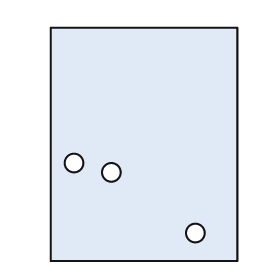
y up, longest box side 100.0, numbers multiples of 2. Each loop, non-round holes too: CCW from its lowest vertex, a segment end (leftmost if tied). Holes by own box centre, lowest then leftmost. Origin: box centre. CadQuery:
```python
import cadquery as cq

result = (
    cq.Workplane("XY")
    .moveTo(-40.0, -50.0)
    .lineTo(40.0, -50.0)
    .lineTo(40.0, 50.0)
    .lineTo(-40.0, 50.0)
    .close()
    .moveTo(22.0, -38.0)
    .circle(4.0)
    .moveTo(-14.0, -12.0)
    .circle(4.0)
    .moveTo(-30.0, -8.0)
    .circle(4.0)
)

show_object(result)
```